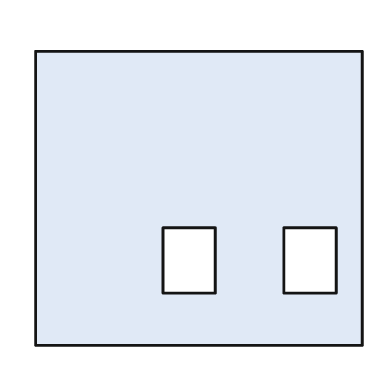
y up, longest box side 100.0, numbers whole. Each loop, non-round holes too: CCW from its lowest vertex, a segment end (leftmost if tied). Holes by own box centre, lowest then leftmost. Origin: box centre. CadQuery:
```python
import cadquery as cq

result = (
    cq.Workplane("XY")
    .moveTo(-50.0, -45.0)
    .lineTo(50.0, -45.0)
    .lineTo(50.0, 45.0)
    .lineTo(-50.0, 45.0)
    .close()
    .moveTo(-11.0, -29.0)
    .lineTo(5.0, -29.0)
    .lineTo(5.0, -9.0)
    .lineTo(-11.0, -9.0)
    .close()
    .moveTo(26.0, -29.0)
    .lineTo(42.0, -29.0)
    .lineTo(42.0, -9.0)
    .lineTo(26.0, -9.0)
    .close()
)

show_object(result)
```